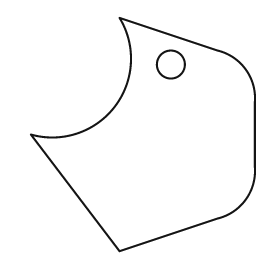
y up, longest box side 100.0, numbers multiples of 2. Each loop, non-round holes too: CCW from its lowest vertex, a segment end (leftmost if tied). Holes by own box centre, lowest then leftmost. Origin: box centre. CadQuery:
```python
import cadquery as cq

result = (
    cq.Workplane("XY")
    .moveTo(-10.0, -50.0)
    .lineTo(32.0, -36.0)
    .threePointArc((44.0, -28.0), (48.0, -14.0))
    .lineTo(48.0, 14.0)
    .threePointArc((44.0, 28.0), (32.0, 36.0))
    .lineTo(-10.0, 50.0)
    .threePointArc((-12.0, 12.0), (-48.0, 0.0))
    .close()
    .moveTo(12.0, 30.0)
    .circle(6.0)
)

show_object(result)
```